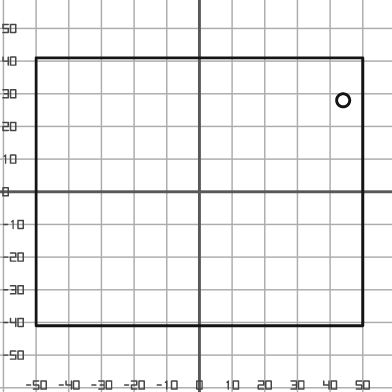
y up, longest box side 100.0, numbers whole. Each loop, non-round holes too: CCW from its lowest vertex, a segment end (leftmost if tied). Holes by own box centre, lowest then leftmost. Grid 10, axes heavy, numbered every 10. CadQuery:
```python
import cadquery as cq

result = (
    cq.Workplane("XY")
    .moveTo(-50.0, -41.0)
    .lineTo(50.0, -41.0)
    .lineTo(50.0, 41.0)
    .lineTo(-50.0, 41.0)
    .close()
    .moveTo(44.0, 28.0)
    .circle(2.0)
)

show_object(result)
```